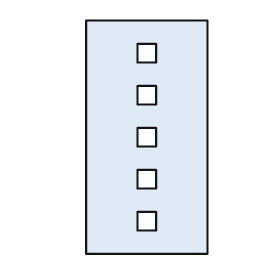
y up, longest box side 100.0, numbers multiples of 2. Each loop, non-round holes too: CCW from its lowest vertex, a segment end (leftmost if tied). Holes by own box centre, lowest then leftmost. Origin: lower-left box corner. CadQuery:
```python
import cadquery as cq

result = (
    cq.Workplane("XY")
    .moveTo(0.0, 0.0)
    .lineTo(52.0, 0.0)
    .lineTo(52.0, 100.0)
    .lineTo(0.0, 100.0)
    .close()
    .moveTo(22.0, 10.0)
    .lineTo(30.0, 10.0)
    .lineTo(30.0, 18.0)
    .lineTo(22.0, 18.0)
    .close()
    .moveTo(22.0, 28.0)
    .lineTo(30.0, 28.0)
    .lineTo(30.0, 36.0)
    .lineTo(22.0, 36.0)
    .close()
    .moveTo(22.0, 46.0)
    .lineTo(30.0, 46.0)
    .lineTo(30.0, 54.0)
    .lineTo(22.0, 54.0)
    .close()
    .moveTo(22.0, 64.0)
    .lineTo(30.0, 64.0)
    .lineTo(30.0, 72.0)
    .lineTo(22.0, 72.0)
    .close()
    .moveTo(22.0, 82.0)
    .lineTo(30.0, 82.0)
    .lineTo(30.0, 90.0)
    .lineTo(22.0, 90.0)
    .close()
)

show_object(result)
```